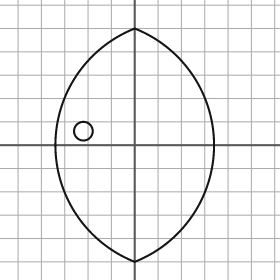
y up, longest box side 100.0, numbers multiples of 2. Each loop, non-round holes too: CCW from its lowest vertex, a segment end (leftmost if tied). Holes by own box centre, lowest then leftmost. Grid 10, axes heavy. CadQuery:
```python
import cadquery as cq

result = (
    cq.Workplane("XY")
    .moveTo(0.0, -50.0)
    .threePointArc((34.0, 0.0), (0.0, 50.0))
    .threePointArc((-34.0, 0.0), (0.0, -50.0))
    .close()
    .moveTo(-22.0, 6.0)
    .circle(4.0)
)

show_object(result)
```